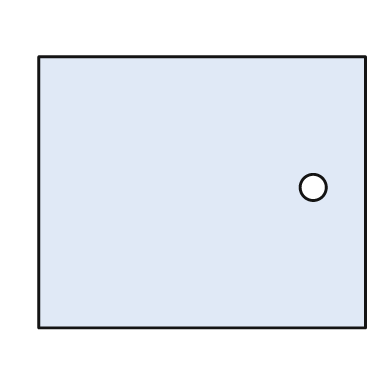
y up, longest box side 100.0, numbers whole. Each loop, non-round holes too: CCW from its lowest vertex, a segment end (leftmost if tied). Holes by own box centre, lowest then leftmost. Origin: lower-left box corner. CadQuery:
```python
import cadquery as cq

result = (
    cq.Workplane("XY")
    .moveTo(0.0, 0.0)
    .lineTo(100.0, 0.0)
    .lineTo(100.0, 83.0)
    .lineTo(0.0, 83.0)
    .close()
    .moveTo(84.0, 43.0)
    .circle(4.0)
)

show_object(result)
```